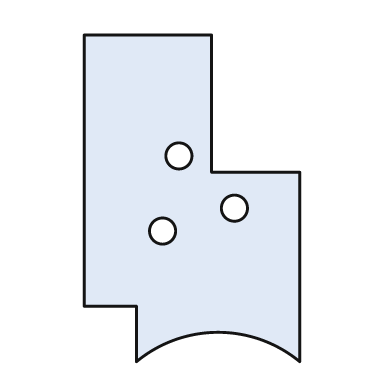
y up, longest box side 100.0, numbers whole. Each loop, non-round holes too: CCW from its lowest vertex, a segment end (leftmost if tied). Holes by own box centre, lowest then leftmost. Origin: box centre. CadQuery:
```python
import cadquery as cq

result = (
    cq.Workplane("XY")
    .moveTo(-17.0, -50.0)
    .threePointArc((8.0, -41.0), (33.0, -50.0))
    .lineTo(33.0, 8.0)
    .lineTo(6.0, 8.0)
    .lineTo(6.0, 50.0)
    .lineTo(-33.0, 50.0)
    .lineTo(-33.0, -33.0)
    .lineTo(-17.0, -33.0)
    .close()
    .moveTo(-9.0, -10.0)
    .circle(4.0)
    .moveTo(13.0, -3.0)
    .circle(4.0)
    .moveTo(-4.0, 13.0)
    .circle(4.0)
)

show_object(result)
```